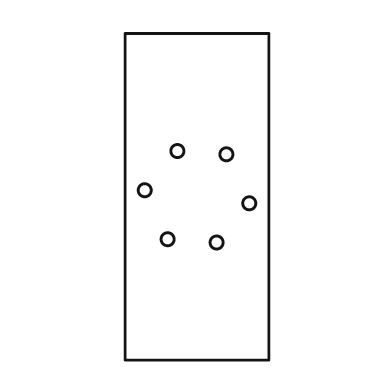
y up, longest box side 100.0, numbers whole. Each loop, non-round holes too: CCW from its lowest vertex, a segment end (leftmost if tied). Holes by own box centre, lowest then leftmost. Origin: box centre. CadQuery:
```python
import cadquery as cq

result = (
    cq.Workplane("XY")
    .moveTo(-22.0, -50.0)
    .lineTo(22.0, -50.0)
    .lineTo(22.0, 50.0)
    .lineTo(-22.0, 50.0)
    .close()
    .moveTo(6.0, -14.0)
    .circle(2.0)
    .moveTo(-9.0, -13.0)
    .circle(2.0)
    .moveTo(16.0, -2.0)
    .circle(2.0)
    .moveTo(-16.0, 2.0)
    .circle(2.0)
    .moveTo(9.0, 13.0)
    .circle(2.0)
    .moveTo(-6.0, 14.0)
    .circle(2.0)
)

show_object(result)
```